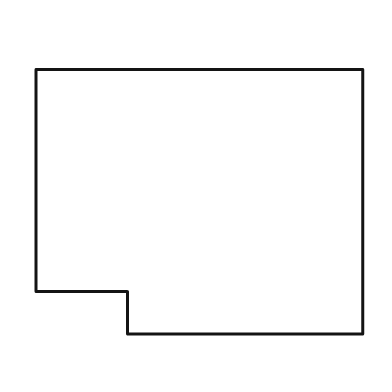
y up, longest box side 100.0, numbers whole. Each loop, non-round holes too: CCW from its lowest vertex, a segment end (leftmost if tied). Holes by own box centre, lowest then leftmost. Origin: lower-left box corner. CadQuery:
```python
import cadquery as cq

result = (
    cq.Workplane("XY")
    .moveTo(28.0, 0.0)
    .lineTo(100.0, 0.0)
    .lineTo(100.0, 81.0)
    .lineTo(0.0, 81.0)
    .lineTo(0.0, 13.0)
    .lineTo(28.0, 13.0)
    .close()
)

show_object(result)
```